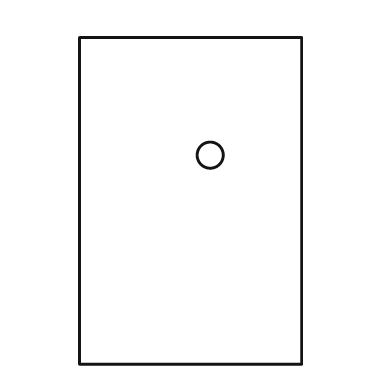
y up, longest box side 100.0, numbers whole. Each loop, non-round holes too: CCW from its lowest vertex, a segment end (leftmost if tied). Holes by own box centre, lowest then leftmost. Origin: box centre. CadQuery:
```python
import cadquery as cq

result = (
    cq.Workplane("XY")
    .moveTo(-34.0, -50.0)
    .lineTo(34.0, -50.0)
    .lineTo(34.0, 50.0)
    .lineTo(-34.0, 50.0)
    .close()
    .moveTo(6.0, 14.0)
    .circle(4.0)
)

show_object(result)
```